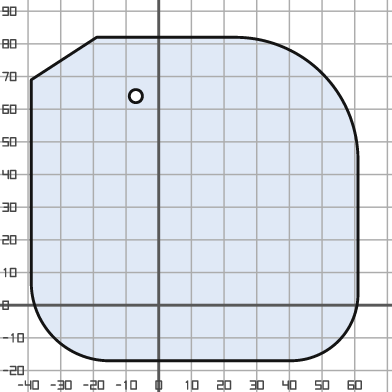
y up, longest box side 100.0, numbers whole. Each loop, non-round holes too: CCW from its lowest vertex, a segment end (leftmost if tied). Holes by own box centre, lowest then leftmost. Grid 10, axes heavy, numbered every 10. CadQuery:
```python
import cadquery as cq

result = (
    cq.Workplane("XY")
    .moveTo(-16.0, -17.0)
    .lineTo(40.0, -17.0)
    .threePointArc((55.0, -11.0), (61.0, 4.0))
    .lineTo(61.0, 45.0)
    .threePointArc((50.0, 71.0), (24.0, 82.0))
    .lineTo(-19.0, 82.0)
    .lineTo(-39.0, 69.0)
    .lineTo(-39.0, 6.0)
    .threePointArc((-32.0, -10.0), (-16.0, -17.0))
    .close()
    .moveTo(-7.0, 64.0)
    .circle(2.0)
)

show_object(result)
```